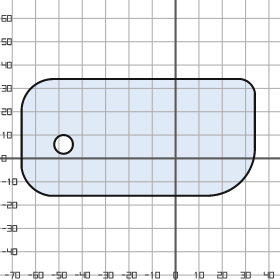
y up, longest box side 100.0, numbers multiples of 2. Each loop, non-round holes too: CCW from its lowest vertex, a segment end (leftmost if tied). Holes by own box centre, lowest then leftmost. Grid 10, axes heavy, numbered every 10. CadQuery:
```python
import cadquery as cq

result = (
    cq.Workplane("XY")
    .moveTo(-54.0, -16.0)
    .lineTo(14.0, -16.0)
    .threePointArc((28.0, -10.0), (34.0, 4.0))
    .lineTo(34.0, 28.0)
    .threePointArc((32.0, 32.0), (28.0, 34.0))
    .lineTo(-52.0, 34.0)
    .threePointArc((-62.0, 30.0), (-66.0, 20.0))
    .lineTo(-66.0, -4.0)
    .threePointArc((-62.0, -12.0), (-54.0, -16.0))
    .close()
    .moveTo(-48.0, 6.0)
    .circle(4.0)
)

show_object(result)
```